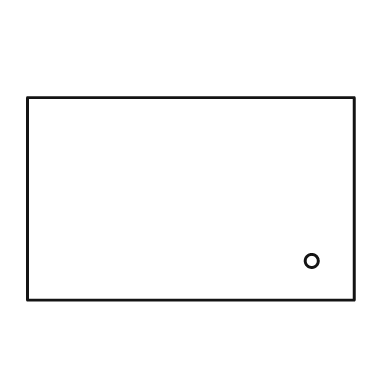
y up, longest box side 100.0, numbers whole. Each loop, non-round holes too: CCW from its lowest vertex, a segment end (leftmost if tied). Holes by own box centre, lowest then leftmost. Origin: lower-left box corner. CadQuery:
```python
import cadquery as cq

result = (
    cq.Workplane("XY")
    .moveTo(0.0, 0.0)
    .lineTo(100.0, 0.0)
    .lineTo(100.0, 62.0)
    .lineTo(0.0, 62.0)
    .close()
    .moveTo(87.0, 12.0)
    .circle(2.0)
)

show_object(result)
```